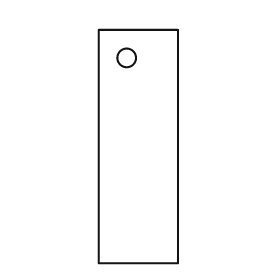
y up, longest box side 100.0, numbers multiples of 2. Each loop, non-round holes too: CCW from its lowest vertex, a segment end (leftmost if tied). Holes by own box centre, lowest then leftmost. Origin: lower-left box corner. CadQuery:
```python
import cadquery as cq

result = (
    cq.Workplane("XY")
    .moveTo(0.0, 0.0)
    .lineTo(34.0, 0.0)
    .lineTo(34.0, 100.0)
    .lineTo(0.0, 100.0)
    .close()
    .moveTo(12.0, 88.0)
    .circle(4.0)
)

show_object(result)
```